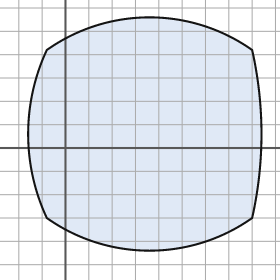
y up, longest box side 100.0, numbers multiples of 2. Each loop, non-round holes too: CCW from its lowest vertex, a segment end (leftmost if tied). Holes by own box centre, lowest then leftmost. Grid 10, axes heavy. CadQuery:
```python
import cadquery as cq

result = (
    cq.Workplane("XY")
    .moveTo(-8.0, -30.0)
    .threePointArc((36.0, -44.0), (80.0, -30.0))
    .threePointArc((84.0, 6.0), (80.0, 42.0))
    .threePointArc((36.0, 56.0), (-8.0, 42.0))
    .threePointArc((-16.0, 6.0), (-8.0, -30.0))
    .close()
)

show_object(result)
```